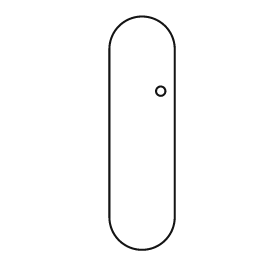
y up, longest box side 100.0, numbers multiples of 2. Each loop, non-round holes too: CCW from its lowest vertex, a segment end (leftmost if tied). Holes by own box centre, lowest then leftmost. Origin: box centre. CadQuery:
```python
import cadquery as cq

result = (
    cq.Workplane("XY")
    .moveTo(-14.0, -36.0)
    .threePointArc((0.0, -50.0), (14.0, -36.0))
    .lineTo(14.0, 36.0)
    .threePointArc((0.0, 50.0), (-14.0, 36.0))
    .close()
    .moveTo(8.0, 18.0)
    .circle(2.0)
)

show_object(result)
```